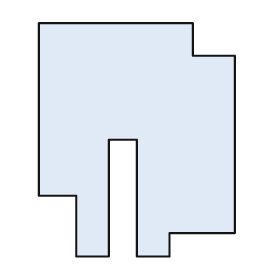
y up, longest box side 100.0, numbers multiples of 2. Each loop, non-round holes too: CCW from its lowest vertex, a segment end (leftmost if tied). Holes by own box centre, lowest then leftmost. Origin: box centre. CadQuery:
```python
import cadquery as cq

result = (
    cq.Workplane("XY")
    .moveTo(-26.0, -50.0)
    .lineTo(-12.0, -50.0)
    .lineTo(-12.0, 0.0)
    .lineTo(0.0, 0.0)
    .lineTo(0.0, -50.0)
    .lineTo(14.0, -50.0)
    .lineTo(14.0, -40.0)
    .lineTo(42.0, -40.0)
    .lineTo(42.0, 36.0)
    .lineTo(24.0, 36.0)
    .lineTo(24.0, 50.0)
    .lineTo(-42.0, 50.0)
    .lineTo(-42.0, -24.0)
    .lineTo(-26.0, -24.0)
    .close()
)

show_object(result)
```